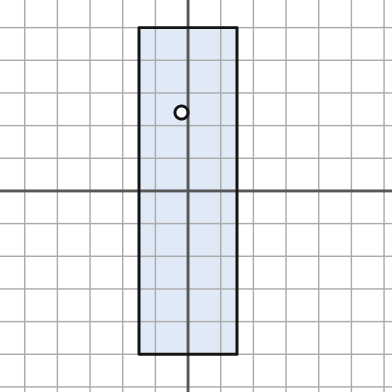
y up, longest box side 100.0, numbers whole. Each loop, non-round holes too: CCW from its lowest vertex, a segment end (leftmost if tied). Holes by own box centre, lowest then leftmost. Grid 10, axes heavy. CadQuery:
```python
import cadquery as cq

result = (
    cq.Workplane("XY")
    .moveTo(-15.0, -50.0)
    .lineTo(15.0, -50.0)
    .lineTo(15.0, 50.0)
    .lineTo(-15.0, 50.0)
    .close()
    .moveTo(-2.0, 24.0)
    .circle(2.0)
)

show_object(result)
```